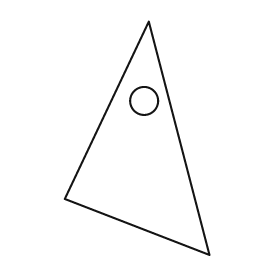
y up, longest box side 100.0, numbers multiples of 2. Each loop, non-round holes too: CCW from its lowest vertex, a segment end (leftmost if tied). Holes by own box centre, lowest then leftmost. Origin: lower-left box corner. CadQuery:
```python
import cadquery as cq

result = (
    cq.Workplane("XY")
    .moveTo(62.0, 0.0)
    .lineTo(36.0, 100.0)
    .lineTo(0.0, 24.0)
    .close()
    .moveTo(34.0, 66.0)
    .circle(6.0)
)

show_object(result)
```